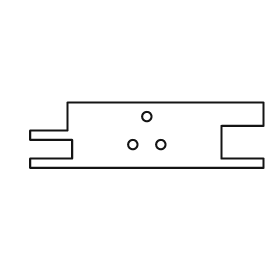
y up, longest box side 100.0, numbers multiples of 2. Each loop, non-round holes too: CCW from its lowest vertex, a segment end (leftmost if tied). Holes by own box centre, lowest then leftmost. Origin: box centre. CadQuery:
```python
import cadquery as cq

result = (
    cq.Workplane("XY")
    .moveTo(-50.0, -14.0)
    .lineTo(50.0, -14.0)
    .lineTo(50.0, -10.0)
    .lineTo(32.0, -10.0)
    .lineTo(32.0, 4.0)
    .lineTo(50.0, 4.0)
    .lineTo(50.0, 14.0)
    .lineTo(-34.0, 14.0)
    .lineTo(-34.0, 2.0)
    .lineTo(-50.0, 2.0)
    .lineTo(-50.0, -2.0)
    .lineTo(-32.0, -2.0)
    .lineTo(-32.0, -10.0)
    .lineTo(-50.0, -10.0)
    .close()
    .moveTo(-6.0, -4.0)
    .circle(2.0)
    .moveTo(6.0, -4.0)
    .circle(2.0)
    .moveTo(0.0, 8.0)
    .circle(2.0)
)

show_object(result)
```